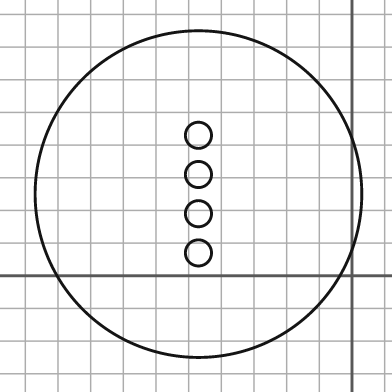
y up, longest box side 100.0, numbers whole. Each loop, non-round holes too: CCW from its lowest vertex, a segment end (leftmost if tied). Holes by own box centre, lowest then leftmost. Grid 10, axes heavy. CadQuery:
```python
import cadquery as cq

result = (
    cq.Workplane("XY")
    .moveTo(-47.0, 25.0)
    .circle(50.0)
    .moveTo(-47.0, 7.0)
    .circle(4.0)
    .moveTo(-47.0, 19.0)
    .circle(4.0)
    .moveTo(-47.0, 31.0)
    .circle(4.0)
    .moveTo(-47.0, 43.0)
    .circle(4.0)
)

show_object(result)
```